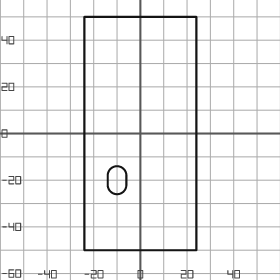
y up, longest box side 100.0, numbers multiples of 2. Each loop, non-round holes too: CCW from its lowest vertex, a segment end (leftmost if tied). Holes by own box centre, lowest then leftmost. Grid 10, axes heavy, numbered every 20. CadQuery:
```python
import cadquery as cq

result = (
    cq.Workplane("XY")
    .moveTo(-24.0, -50.0)
    .lineTo(24.0, -50.0)
    .lineTo(24.0, 50.0)
    .lineTo(-24.0, 50.0)
    .close()
    .moveTo(-14.0, -22.0)
    .threePointArc((-10.0, -26.0), (-6.0, -22.0))
    .lineTo(-6.0, -18.0)
    .threePointArc((-10.0, -14.0), (-14.0, -18.0))
    .close()
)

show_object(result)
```